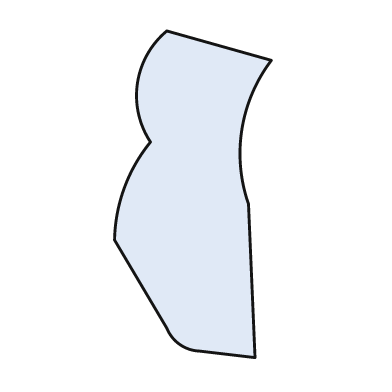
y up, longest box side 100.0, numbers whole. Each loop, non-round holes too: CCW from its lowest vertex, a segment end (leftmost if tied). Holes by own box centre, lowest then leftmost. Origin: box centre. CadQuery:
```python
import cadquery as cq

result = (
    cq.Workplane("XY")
    .moveTo(19.0, -50.0)
    .lineTo(17.0, -3.0)
    .threePointArc((15.0, 20.0), (24.0, 41.0))
    .lineTo(-8.0, 50.0)
    .threePointArc((-17.0, 34.0), (-13.0, 16.0))
    .threePointArc((-21.0, 2.0), (-24.0, -14.0))
    .lineTo(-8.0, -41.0)
    .threePointArc((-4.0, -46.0), (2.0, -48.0))
    .close()
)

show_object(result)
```